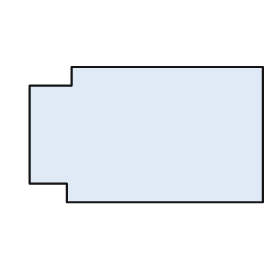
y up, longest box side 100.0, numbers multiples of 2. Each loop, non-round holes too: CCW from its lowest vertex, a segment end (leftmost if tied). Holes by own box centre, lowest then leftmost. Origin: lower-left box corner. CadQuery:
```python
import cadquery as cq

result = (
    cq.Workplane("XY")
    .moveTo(16.0, 0.0)
    .lineTo(100.0, 0.0)
    .lineTo(100.0, 58.0)
    .lineTo(18.0, 58.0)
    .lineTo(18.0, 50.0)
    .lineTo(0.0, 50.0)
    .lineTo(0.0, 8.0)
    .lineTo(16.0, 8.0)
    .close()
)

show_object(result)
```